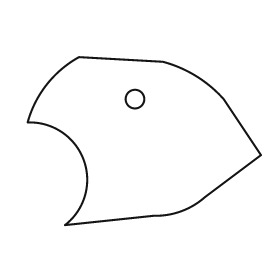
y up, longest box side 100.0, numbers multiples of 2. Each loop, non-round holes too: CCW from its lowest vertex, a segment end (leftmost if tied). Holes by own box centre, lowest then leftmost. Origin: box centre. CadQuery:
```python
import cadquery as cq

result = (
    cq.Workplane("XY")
    .moveTo(-34.0, -36.0)
    .lineTo(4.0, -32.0)
    .threePointArc((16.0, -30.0), (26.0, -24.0))
    .lineTo(50.0, -6.0)
    .lineTo(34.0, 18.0)
    .threePointArc((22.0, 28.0), (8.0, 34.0))
    .lineTo(-28.0, 36.0)
    .threePointArc((-42.0, 24.0), (-50.0, 8.0))
    .threePointArc((-26.0, -8.0), (-34.0, -36.0))
    .close()
    .moveTo(-4.0, 18.0)
    .circle(4.0)
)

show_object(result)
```